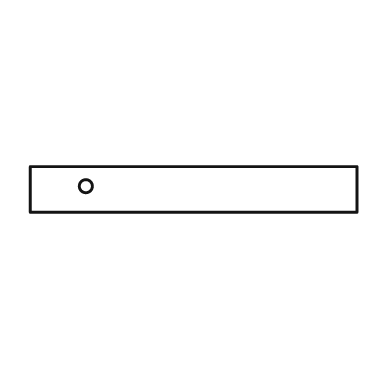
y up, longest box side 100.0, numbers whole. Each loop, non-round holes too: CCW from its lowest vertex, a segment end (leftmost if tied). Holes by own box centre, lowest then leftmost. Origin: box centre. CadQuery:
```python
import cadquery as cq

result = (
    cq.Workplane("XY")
    .moveTo(-50.0, -7.0)
    .lineTo(50.0, -7.0)
    .lineTo(50.0, 7.0)
    .lineTo(-50.0, 7.0)
    .close()
    .moveTo(-33.0, 1.0)
    .circle(2.0)
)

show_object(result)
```